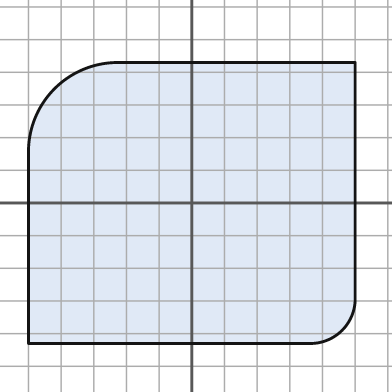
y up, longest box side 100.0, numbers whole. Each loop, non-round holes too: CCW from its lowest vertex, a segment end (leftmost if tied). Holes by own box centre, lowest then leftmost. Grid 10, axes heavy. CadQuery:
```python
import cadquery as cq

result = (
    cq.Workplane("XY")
    .moveTo(-50.0, -43.0)
    .lineTo(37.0, -43.0)
    .threePointArc((46.0, -39.0), (50.0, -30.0))
    .lineTo(50.0, 43.0)
    .lineTo(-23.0, 43.0)
    .threePointArc((-42.0, 35.0), (-50.0, 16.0))
    .close()
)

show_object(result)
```